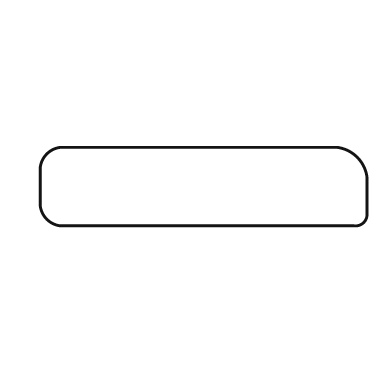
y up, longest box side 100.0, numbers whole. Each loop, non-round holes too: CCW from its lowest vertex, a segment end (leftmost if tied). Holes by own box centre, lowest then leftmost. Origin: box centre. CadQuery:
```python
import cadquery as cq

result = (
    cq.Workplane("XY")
    .moveTo(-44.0, -12.0)
    .lineTo(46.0, -12.0)
    .threePointArc((49.0, -11.0), (50.0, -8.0))
    .lineTo(50.0, 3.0)
    .threePointArc((47.0, 9.0), (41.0, 12.0))
    .lineTo(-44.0, 12.0)
    .threePointArc((-48.0, 10.0), (-50.0, 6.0))
    .lineTo(-50.0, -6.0)
    .threePointArc((-48.0, -10.0), (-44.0, -12.0))
    .close()
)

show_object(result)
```